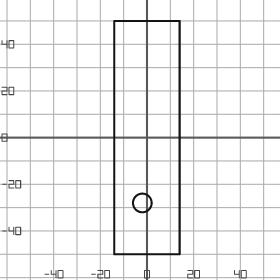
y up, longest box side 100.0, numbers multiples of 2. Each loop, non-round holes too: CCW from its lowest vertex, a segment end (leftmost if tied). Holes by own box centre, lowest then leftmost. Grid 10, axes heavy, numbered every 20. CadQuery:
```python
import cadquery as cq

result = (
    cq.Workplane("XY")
    .moveTo(-14.0, -50.0)
    .lineTo(14.0, -50.0)
    .lineTo(14.0, 50.0)
    .lineTo(-14.0, 50.0)
    .close()
    .moveTo(-2.0, -28.0)
    .circle(4.0)
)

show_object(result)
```